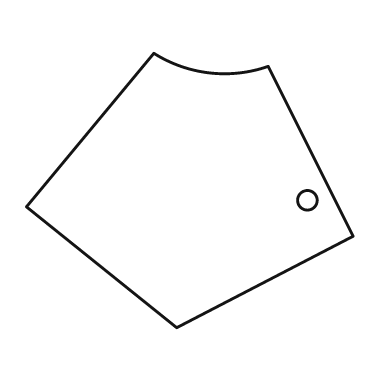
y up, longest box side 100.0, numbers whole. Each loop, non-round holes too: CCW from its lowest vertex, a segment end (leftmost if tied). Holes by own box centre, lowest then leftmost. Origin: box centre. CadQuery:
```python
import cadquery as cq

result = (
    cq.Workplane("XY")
    .moveTo(-4.0, -42.0)
    .lineTo(50.0, -14.0)
    .lineTo(24.0, 38.0)
    .threePointArc((6.0, 36.0), (-11.0, 42.0))
    .lineTo(-50.0, -5.0)
    .close()
    .moveTo(36.0, -3.0)
    .circle(3.0)
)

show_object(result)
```